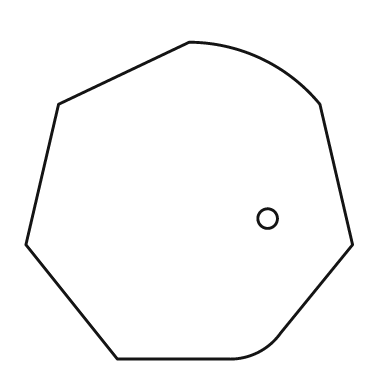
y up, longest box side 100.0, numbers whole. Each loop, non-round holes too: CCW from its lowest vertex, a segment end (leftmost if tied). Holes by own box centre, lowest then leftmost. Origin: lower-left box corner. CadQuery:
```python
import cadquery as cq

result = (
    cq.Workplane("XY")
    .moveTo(28.0, 0.0)
    .lineTo(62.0, 0.0)
    .threePointArc((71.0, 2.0), (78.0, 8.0))
    .lineTo(100.0, 35.0)
    .lineTo(90.0, 78.0)
    .threePointArc((72.0, 92.0), (50.0, 97.0))
    .lineTo(10.0, 78.0)
    .lineTo(0.0, 35.0)
    .close()
    .moveTo(74.0, 43.0)
    .circle(3.0)
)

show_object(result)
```